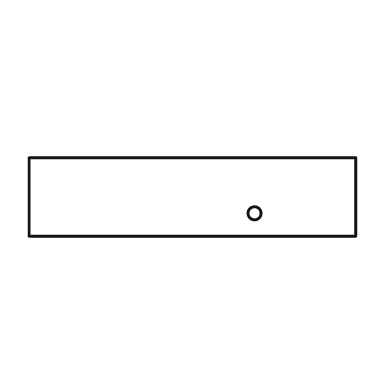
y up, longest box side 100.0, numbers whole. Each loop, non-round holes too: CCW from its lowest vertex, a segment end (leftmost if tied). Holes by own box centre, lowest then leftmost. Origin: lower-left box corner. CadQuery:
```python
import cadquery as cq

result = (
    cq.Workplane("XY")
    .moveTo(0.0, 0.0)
    .lineTo(100.0, 0.0)
    .lineTo(100.0, 24.0)
    .lineTo(0.0, 24.0)
    .close()
    .moveTo(69.0, 7.0)
    .circle(2.0)
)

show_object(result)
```